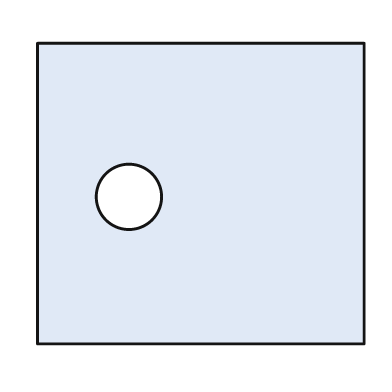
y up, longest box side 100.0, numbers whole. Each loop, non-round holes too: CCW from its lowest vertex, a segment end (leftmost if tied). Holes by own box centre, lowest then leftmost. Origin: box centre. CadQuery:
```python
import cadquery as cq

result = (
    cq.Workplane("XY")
    .moveTo(-50.0, -46.0)
    .lineTo(50.0, -46.0)
    .lineTo(50.0, 46.0)
    .lineTo(-50.0, 46.0)
    .close()
    .moveTo(-22.0, -1.0)
    .circle(10.0)
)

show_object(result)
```